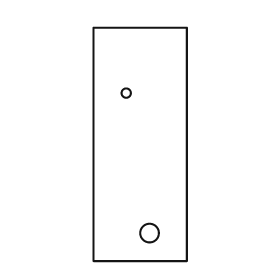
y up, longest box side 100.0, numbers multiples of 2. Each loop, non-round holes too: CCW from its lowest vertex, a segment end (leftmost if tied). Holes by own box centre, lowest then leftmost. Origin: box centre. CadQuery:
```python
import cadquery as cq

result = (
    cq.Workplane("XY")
    .moveTo(-20.0, -50.0)
    .lineTo(20.0, -50.0)
    .lineTo(20.0, 50.0)
    .lineTo(-20.0, 50.0)
    .close()
    .moveTo(4.0, -38.0)
    .circle(4.0)
    .moveTo(-6.0, 22.0)
    .circle(2.0)
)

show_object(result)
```